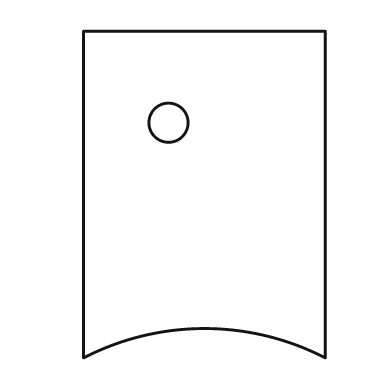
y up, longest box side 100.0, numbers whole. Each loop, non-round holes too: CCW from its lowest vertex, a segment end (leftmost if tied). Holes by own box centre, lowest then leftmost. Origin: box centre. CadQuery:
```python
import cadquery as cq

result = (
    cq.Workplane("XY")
    .moveTo(-37.0, -50.0)
    .threePointArc((0.0, -41.0), (37.0, -50.0))
    .lineTo(37.0, 50.0)
    .lineTo(-37.0, 50.0)
    .close()
    .moveTo(-11.0, 22.0)
    .circle(6.0)
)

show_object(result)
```